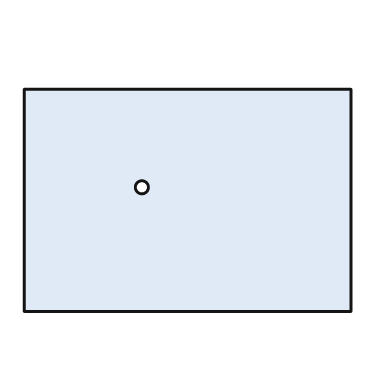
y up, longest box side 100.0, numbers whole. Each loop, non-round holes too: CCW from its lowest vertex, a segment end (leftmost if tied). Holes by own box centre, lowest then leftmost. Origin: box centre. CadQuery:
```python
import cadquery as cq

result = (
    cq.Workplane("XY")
    .moveTo(-50.0, -34.0)
    .lineTo(50.0, -34.0)
    .lineTo(50.0, 34.0)
    .lineTo(-50.0, 34.0)
    .close()
    .moveTo(-14.0, 4.0)
    .circle(2.0)
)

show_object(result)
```